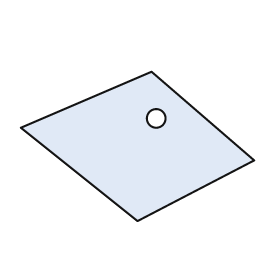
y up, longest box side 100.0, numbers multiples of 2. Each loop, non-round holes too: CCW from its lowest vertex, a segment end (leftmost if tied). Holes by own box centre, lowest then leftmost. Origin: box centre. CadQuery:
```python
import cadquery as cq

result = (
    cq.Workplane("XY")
    .moveTo(0.0, -32.0)
    .lineTo(50.0, -6.0)
    .lineTo(6.0, 32.0)
    .lineTo(-50.0, 8.0)
    .close()
    .moveTo(8.0, 12.0)
    .circle(4.0)
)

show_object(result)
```